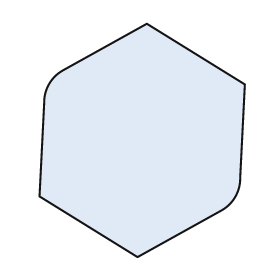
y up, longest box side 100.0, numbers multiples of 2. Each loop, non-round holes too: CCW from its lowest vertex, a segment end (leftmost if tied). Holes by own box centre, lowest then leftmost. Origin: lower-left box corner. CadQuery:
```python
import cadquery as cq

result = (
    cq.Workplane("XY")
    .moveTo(42.0, 0.0)
    .lineTo(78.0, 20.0)
    .threePointArc((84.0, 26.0), (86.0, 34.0))
    .lineTo(88.0, 74.0)
    .lineTo(46.0, 100.0)
    .lineTo(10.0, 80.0)
    .threePointArc((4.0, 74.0), (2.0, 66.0))
    .lineTo(0.0, 26.0)
    .close()
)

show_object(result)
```